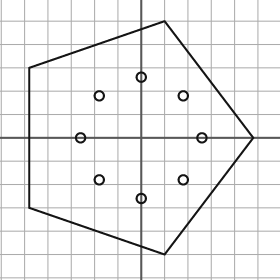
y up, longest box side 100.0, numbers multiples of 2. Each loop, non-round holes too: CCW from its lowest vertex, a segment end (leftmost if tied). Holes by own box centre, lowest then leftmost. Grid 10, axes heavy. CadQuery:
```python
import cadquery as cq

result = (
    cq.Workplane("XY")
    .moveTo(10.0, -50.0)
    .lineTo(48.0, 0.0)
    .lineTo(10.0, 50.0)
    .lineTo(-48.0, 30.0)
    .lineTo(-48.0, -30.0)
    .close()
    .moveTo(0.0, -26.0)
    .circle(2.0)
    .moveTo(-18.0, -18.0)
    .circle(2.0)
    .moveTo(18.0, -18.0)
    .circle(2.0)
    .moveTo(-26.0, 0.0)
    .circle(2.0)
    .moveTo(26.0, 0.0)
    .circle(2.0)
    .moveTo(-18.0, 18.0)
    .circle(2.0)
    .moveTo(18.0, 18.0)
    .circle(2.0)
    .moveTo(0.0, 26.0)
    .circle(2.0)
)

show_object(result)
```